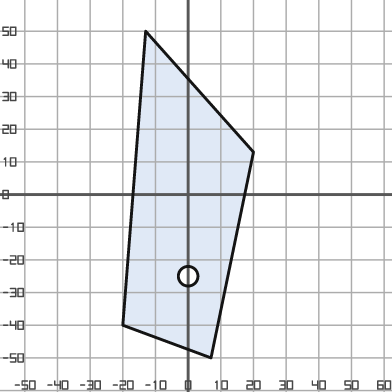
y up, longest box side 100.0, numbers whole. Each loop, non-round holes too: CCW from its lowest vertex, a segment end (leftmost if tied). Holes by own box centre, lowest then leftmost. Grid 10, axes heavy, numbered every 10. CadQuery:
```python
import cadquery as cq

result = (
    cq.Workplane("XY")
    .moveTo(7.0, -50.0)
    .lineTo(20.0, 13.0)
    .lineTo(-13.0, 50.0)
    .lineTo(-20.0, -40.0)
    .close()
    .moveTo(0.0, -25.0)
    .circle(3.0)
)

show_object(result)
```